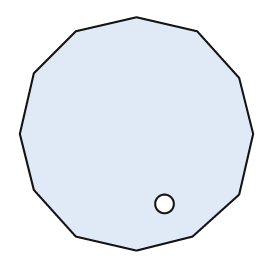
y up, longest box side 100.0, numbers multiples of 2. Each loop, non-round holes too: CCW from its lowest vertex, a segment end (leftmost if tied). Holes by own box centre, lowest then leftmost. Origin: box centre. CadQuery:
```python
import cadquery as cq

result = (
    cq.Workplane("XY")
    .moveTo(0.0, -50.0)
    .lineTo(24.0, -44.0)
    .lineTo(44.0, -26.0)
    .lineTo(50.0, 0.0)
    .lineTo(44.0, 24.0)
    .lineTo(26.0, 44.0)
    .lineTo(0.0, 50.0)
    .lineTo(-26.0, 44.0)
    .lineTo(-44.0, 26.0)
    .lineTo(-50.0, 0.0)
    .lineTo(-44.0, -24.0)
    .lineTo(-26.0, -44.0)
    .close()
    .moveTo(12.0, -30.0)
    .circle(4.0)
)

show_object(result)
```